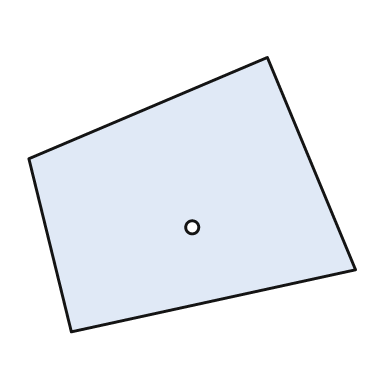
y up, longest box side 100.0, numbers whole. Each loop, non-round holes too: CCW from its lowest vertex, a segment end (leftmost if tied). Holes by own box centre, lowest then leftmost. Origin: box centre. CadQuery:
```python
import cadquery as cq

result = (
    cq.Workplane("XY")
    .moveTo(-37.0, -42.0)
    .lineTo(50.0, -23.0)
    .lineTo(23.0, 42.0)
    .lineTo(-50.0, 11.0)
    .close()
    .moveTo(0.0, -10.0)
    .circle(2.0)
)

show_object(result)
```